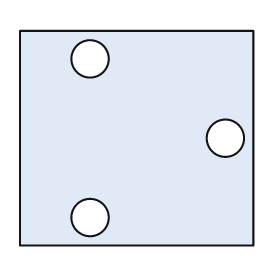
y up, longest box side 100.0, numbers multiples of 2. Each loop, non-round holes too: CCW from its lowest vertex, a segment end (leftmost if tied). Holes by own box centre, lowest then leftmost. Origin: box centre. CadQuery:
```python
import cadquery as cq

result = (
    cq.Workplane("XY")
    .moveTo(-50.0, -46.0)
    .lineTo(50.0, -46.0)
    .lineTo(50.0, 46.0)
    .lineTo(-50.0, 46.0)
    .close()
    .moveTo(-20.0, -34.0)
    .circle(8.0)
    .moveTo(38.0, 0.0)
    .circle(8.0)
    .moveTo(-20.0, 34.0)
    .circle(8.0)
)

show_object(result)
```